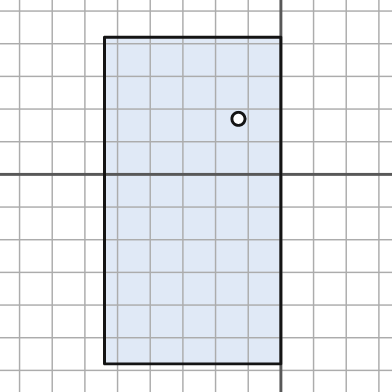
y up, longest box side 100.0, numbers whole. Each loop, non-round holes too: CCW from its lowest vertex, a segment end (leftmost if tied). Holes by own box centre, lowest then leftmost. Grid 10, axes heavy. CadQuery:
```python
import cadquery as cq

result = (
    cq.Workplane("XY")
    .moveTo(-54.0, -58.0)
    .lineTo(0.0, -58.0)
    .lineTo(0.0, 42.0)
    .lineTo(-54.0, 42.0)
    .close()
    .moveTo(-13.0, 17.0)
    .circle(2.0)
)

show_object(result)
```